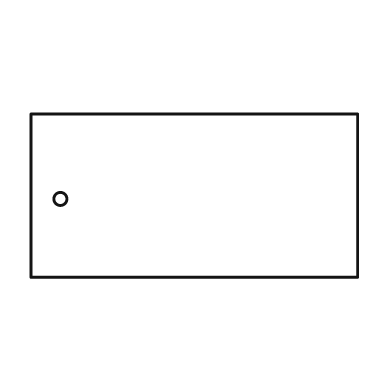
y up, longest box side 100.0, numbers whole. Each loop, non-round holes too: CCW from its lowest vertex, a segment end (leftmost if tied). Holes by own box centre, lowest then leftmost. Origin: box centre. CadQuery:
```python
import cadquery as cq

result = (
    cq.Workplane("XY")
    .moveTo(-50.0, -25.0)
    .lineTo(50.0, -25.0)
    .lineTo(50.0, 25.0)
    .lineTo(-50.0, 25.0)
    .close()
    .moveTo(-41.0, -1.0)
    .circle(2.0)
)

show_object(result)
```